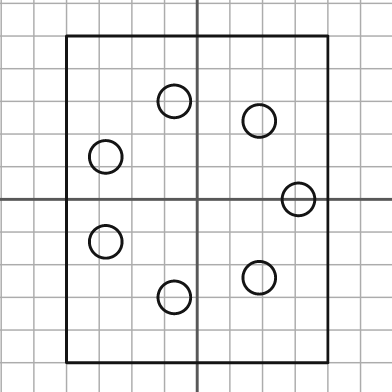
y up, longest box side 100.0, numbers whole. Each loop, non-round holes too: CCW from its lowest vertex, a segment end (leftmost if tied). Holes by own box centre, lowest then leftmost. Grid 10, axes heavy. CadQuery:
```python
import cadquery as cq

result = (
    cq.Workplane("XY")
    .moveTo(-40.0, -50.0)
    .lineTo(40.0, -50.0)
    .lineTo(40.0, 50.0)
    .lineTo(-40.0, 50.0)
    .close()
    .moveTo(-7.0, -30.0)
    .circle(5.0)
    .moveTo(19.0, -24.0)
    .circle(5.0)
    .moveTo(-28.0, -13.0)
    .circle(5.0)
    .moveTo(31.0, 0.0)
    .circle(5.0)
    .moveTo(-28.0, 13.0)
    .circle(5.0)
    .moveTo(19.0, 24.0)
    .circle(5.0)
    .moveTo(-7.0, 30.0)
    .circle(5.0)
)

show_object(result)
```